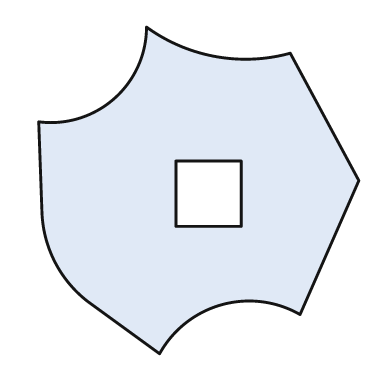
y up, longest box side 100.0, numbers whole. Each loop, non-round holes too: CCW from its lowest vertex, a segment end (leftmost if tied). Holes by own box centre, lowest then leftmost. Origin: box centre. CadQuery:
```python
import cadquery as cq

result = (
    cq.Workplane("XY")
    .moveTo(-12.0, -50.0)
    .threePointArc((7.0, -35.0), (31.0, -38.0))
    .lineTo(49.0, 3.0)
    .lineTo(28.0, 42.0)
    .threePointArc((5.0, 41.0), (-16.0, 50.0))
    .threePointArc((-26.0, 28.0), (-49.0, 21.0))
    .lineTo(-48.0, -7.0)
    .threePointArc((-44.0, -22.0), (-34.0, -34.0))
    .close()
    .moveTo(-7.0, -11.0)
    .lineTo(13.0, -11.0)
    .lineTo(13.0, 9.0)
    .lineTo(-7.0, 9.0)
    .close()
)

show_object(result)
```